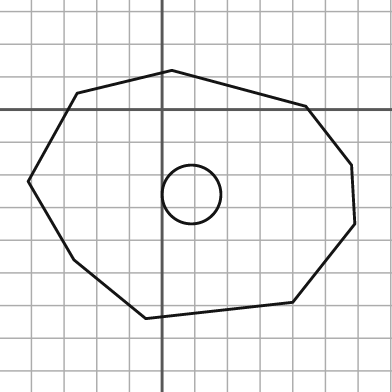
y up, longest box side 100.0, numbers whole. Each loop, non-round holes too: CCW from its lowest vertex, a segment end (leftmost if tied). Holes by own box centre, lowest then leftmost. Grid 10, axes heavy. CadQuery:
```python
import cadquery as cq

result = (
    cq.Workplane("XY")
    .moveTo(-5.0, -64.0)
    .lineTo(40.0, -59.0)
    .lineTo(59.0, -35.0)
    .lineTo(58.0, -17.0)
    .lineTo(44.0, 1.0)
    .lineTo(3.0, 12.0)
    .lineTo(-26.0, 5.0)
    .lineTo(-41.0, -22.0)
    .lineTo(-27.0, -46.0)
    .close()
    .moveTo(9.0, -26.0)
    .circle(9.0)
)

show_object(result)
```